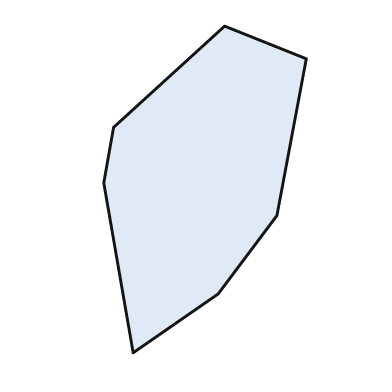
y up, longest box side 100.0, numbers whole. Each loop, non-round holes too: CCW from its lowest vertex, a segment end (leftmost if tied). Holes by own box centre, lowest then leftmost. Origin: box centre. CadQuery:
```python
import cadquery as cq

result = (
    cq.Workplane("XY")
    .moveTo(-22.0, -50.0)
    .lineTo(4.0, -32.0)
    .lineTo(22.0, -8.0)
    .lineTo(31.0, 40.0)
    .lineTo(6.0, 50.0)
    .lineTo(-28.0, 19.0)
    .lineTo(-31.0, 2.0)
    .close()
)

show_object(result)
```